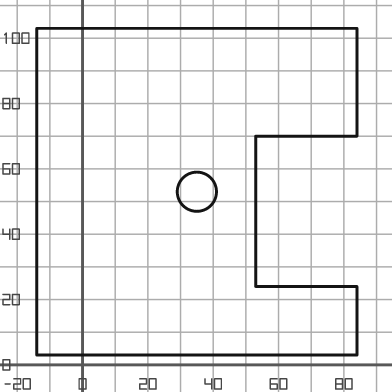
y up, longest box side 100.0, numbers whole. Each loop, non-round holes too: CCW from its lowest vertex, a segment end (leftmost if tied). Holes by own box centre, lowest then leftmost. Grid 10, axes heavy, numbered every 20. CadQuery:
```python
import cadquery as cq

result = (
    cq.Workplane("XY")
    .moveTo(-14.0, 3.0)
    .lineTo(84.0, 3.0)
    .lineTo(84.0, 24.0)
    .lineTo(53.0, 24.0)
    .lineTo(53.0, 70.0)
    .lineTo(84.0, 70.0)
    .lineTo(84.0, 103.0)
    .lineTo(-14.0, 103.0)
    .close()
    .moveTo(35.0, 53.0)
    .circle(6.0)
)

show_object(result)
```